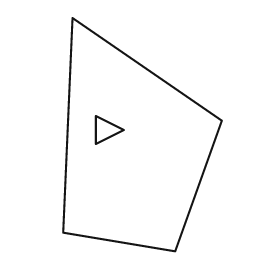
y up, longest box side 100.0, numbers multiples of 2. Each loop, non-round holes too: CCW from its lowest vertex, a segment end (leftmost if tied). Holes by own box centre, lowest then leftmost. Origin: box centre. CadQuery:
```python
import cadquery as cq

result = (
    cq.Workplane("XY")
    .moveTo(14.0, -50.0)
    .lineTo(34.0, 6.0)
    .lineTo(-30.0, 50.0)
    .lineTo(-34.0, -42.0)
    .close()
    .moveTo(-20.0, -4.0)
    .lineTo(-8.0, 2.0)
    .lineTo(-20.0, 8.0)
    .close()
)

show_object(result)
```